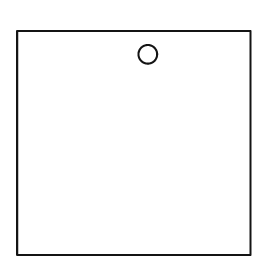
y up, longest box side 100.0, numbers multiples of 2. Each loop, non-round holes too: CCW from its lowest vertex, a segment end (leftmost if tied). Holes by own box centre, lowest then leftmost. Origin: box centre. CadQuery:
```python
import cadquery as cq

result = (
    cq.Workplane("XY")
    .moveTo(-50.0, -48.0)
    .lineTo(50.0, -48.0)
    .lineTo(50.0, 48.0)
    .lineTo(-50.0, 48.0)
    .close()
    .moveTo(6.0, 38.0)
    .circle(4.0)
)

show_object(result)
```